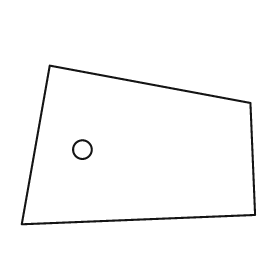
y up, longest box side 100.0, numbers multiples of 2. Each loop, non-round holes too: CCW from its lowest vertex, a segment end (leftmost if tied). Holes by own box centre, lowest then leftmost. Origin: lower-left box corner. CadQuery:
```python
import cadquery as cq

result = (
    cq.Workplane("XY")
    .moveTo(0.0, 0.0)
    .lineTo(100.0, 4.0)
    .lineTo(98.0, 52.0)
    .lineTo(12.0, 68.0)
    .close()
    .moveTo(26.0, 32.0)
    .circle(4.0)
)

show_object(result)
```